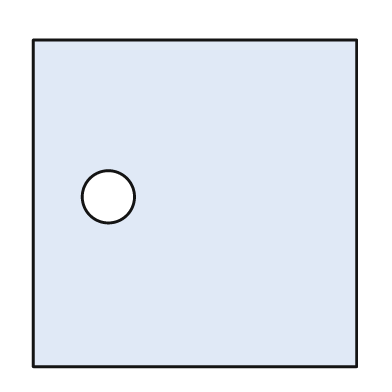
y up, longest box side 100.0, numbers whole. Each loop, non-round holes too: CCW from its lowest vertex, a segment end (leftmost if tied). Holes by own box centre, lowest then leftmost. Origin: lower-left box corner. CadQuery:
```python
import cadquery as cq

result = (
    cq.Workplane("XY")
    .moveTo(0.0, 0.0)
    .lineTo(99.0, 0.0)
    .lineTo(99.0, 100.0)
    .lineTo(0.0, 100.0)
    .close()
    .moveTo(23.0, 52.0)
    .circle(8.0)
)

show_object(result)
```